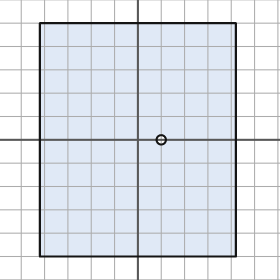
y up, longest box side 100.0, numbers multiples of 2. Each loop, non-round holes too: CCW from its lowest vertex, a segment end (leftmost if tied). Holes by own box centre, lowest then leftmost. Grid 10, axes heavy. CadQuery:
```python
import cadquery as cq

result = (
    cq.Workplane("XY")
    .moveTo(-42.0, -50.0)
    .lineTo(42.0, -50.0)
    .lineTo(42.0, 50.0)
    .lineTo(-42.0, 50.0)
    .close()
    .moveTo(10.0, 0.0)
    .circle(2.0)
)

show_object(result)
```